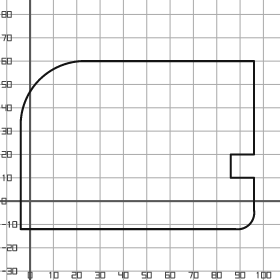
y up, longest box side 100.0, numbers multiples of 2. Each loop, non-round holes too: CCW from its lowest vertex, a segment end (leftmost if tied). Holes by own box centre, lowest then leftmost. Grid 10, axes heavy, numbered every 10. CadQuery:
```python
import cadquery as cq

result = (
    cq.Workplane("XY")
    .moveTo(-4.0, -12.0)
    .lineTo(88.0, -12.0)
    .threePointArc((94.0, -10.0), (96.0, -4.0))
    .lineTo(96.0, 10.0)
    .lineTo(86.0, 10.0)
    .lineTo(86.0, 20.0)
    .lineTo(96.0, 20.0)
    .lineTo(96.0, 60.0)
    .lineTo(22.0, 60.0)
    .threePointArc((4.0, 52.0), (-4.0, 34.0))
    .close()
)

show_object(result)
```